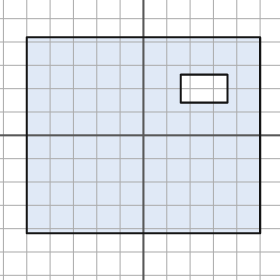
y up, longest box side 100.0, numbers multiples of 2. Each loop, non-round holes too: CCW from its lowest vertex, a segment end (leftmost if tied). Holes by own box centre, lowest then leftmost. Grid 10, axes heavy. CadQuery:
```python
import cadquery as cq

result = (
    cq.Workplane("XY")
    .moveTo(-50.0, -42.0)
    .lineTo(50.0, -42.0)
    .lineTo(50.0, 42.0)
    .lineTo(-50.0, 42.0)
    .close()
    .moveTo(16.0, 14.0)
    .lineTo(36.0, 14.0)
    .lineTo(36.0, 26.0)
    .lineTo(16.0, 26.0)
    .close()
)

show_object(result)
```